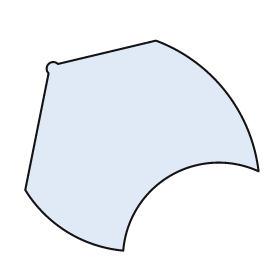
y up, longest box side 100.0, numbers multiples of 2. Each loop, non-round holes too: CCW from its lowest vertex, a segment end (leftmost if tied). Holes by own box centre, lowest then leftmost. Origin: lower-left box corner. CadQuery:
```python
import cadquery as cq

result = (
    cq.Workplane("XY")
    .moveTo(42.0, 0.0)
    .threePointArc((62.0, 32.0), (100.0, 34.0))
    .threePointArc((86.0, 68.0), (56.0, 90.0))
    .lineTo(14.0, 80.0)
    .threePointArc((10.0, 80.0), (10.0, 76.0))
    .lineTo(0.0, 26.0)
    .threePointArc((18.0, 8.0), (42.0, 0.0))
    .close()
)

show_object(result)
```